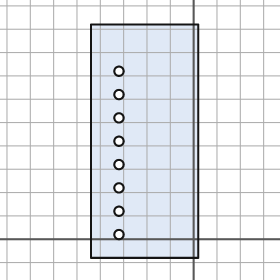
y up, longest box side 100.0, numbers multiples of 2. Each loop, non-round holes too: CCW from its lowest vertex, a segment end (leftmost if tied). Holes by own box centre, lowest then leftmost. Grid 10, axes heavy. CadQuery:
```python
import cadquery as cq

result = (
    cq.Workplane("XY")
    .moveTo(-44.0, -8.0)
    .lineTo(2.0, -8.0)
    .lineTo(2.0, 92.0)
    .lineTo(-44.0, 92.0)
    .close()
    .moveTo(-32.0, 2.0)
    .circle(2.0)
    .moveTo(-32.0, 12.0)
    .circle(2.0)
    .moveTo(-32.0, 22.0)
    .circle(2.0)
    .moveTo(-32.0, 32.0)
    .circle(2.0)
    .moveTo(-32.0, 42.0)
    .circle(2.0)
    .moveTo(-32.0, 52.0)
    .circle(2.0)
    .moveTo(-32.0, 62.0)
    .circle(2.0)
    .moveTo(-32.0, 72.0)
    .circle(2.0)
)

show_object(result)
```